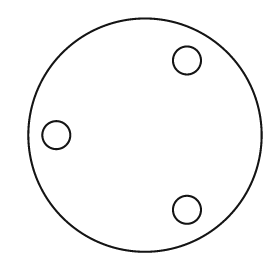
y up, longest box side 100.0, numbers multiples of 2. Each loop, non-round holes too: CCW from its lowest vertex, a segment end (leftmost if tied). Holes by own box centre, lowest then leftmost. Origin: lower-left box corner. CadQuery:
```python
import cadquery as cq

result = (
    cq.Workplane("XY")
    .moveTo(50.0, 50.0)
    .circle(50.0)
    .moveTo(68.0, 18.0)
    .circle(6.0)
    .moveTo(12.0, 50.0)
    .circle(6.0)
    .moveTo(68.0, 82.0)
    .circle(6.0)
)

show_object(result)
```